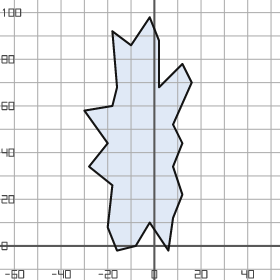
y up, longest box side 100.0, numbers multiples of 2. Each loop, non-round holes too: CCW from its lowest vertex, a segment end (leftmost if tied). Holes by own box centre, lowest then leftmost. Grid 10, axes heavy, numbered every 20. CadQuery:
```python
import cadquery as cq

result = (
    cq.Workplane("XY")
    .moveTo(-16.0, -2.0)
    .lineTo(-8.0, 0.0)
    .lineTo(-2.0, 10.0)
    .lineTo(6.0, -2.0)
    .lineTo(8.0, 12.0)
    .lineTo(12.0, 22.0)
    .lineTo(8.0, 34.0)
    .lineTo(12.0, 44.0)
    .lineTo(8.0, 52.0)
    .lineTo(16.0, 70.0)
    .lineTo(12.0, 78.0)
    .lineTo(2.0, 68.0)
    .lineTo(2.0, 88.0)
    .lineTo(-2.0, 98.0)
    .lineTo(-10.0, 86.0)
    .lineTo(-18.0, 92.0)
    .lineTo(-16.0, 68.0)
    .lineTo(-18.0, 60.0)
    .lineTo(-30.0, 58.0)
    .lineTo(-20.0, 44.0)
    .lineTo(-28.0, 34.0)
    .lineTo(-18.0, 26.0)
    .lineTo(-20.0, 8.0)
    .close()
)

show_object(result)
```